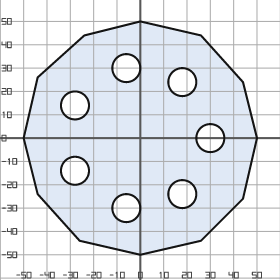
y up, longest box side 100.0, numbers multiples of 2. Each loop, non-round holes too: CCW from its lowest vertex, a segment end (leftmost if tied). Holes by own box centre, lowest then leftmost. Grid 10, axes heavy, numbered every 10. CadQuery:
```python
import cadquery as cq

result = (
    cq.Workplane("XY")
    .moveTo(0.0, -50.0)
    .lineTo(26.0, -44.0)
    .lineTo(44.0, -26.0)
    .lineTo(50.0, 0.0)
    .lineTo(44.0, 24.0)
    .lineTo(26.0, 44.0)
    .lineTo(0.0, 50.0)
    .lineTo(-24.0, 44.0)
    .lineTo(-44.0, 26.0)
    .lineTo(-50.0, 0.0)
    .lineTo(-44.0, -24.0)
    .lineTo(-26.0, -44.0)
    .close()
    .moveTo(-6.0, -30.0)
    .circle(6.0)
    .moveTo(18.0, -24.0)
    .circle(6.0)
    .moveTo(-28.0, -14.0)
    .circle(6.0)
    .moveTo(30.0, 0.0)
    .circle(6.0)
    .moveTo(-28.0, 14.0)
    .circle(6.0)
    .moveTo(18.0, 24.0)
    .circle(6.0)
    .moveTo(-6.0, 30.0)
    .circle(6.0)
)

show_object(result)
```